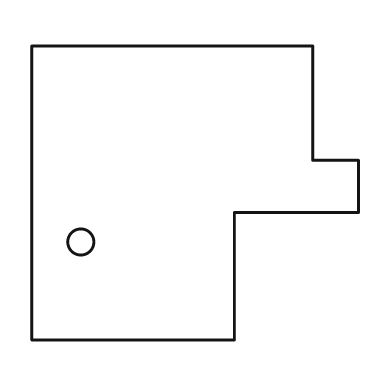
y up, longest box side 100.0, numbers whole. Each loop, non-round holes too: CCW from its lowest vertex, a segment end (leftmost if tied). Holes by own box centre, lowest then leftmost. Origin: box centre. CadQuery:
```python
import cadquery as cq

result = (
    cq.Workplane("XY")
    .moveTo(-50.0, -45.0)
    .lineTo(12.0, -45.0)
    .lineTo(12.0, -6.0)
    .lineTo(50.0, -6.0)
    .lineTo(50.0, 10.0)
    .lineTo(36.0, 10.0)
    .lineTo(36.0, 45.0)
    .lineTo(-50.0, 45.0)
    .close()
    .moveTo(-35.0, -15.0)
    .circle(4.0)
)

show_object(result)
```